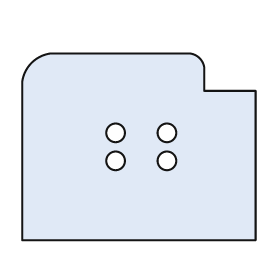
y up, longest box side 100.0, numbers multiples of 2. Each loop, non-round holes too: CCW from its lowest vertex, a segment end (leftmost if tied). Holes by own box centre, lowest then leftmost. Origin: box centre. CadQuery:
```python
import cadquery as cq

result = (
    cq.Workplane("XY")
    .moveTo(-50.0, -40.0)
    .lineTo(50.0, -40.0)
    .lineTo(50.0, 24.0)
    .lineTo(28.0, 24.0)
    .lineTo(28.0, 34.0)
    .threePointArc((26.0, 38.0), (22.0, 40.0))
    .lineTo(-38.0, 40.0)
    .threePointArc((-46.0, 36.0), (-50.0, 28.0))
    .close()
    .moveTo(-10.0, -6.0)
    .circle(4.0)
    .moveTo(12.0, -6.0)
    .circle(4.0)
    .moveTo(-10.0, 6.0)
    .circle(4.0)
    .moveTo(12.0, 6.0)
    .circle(4.0)
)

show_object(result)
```